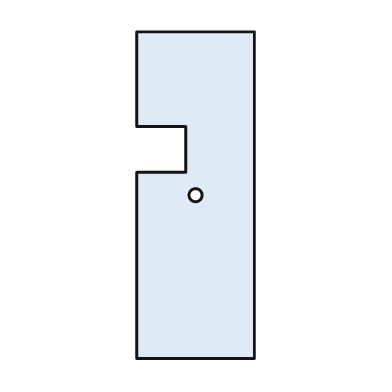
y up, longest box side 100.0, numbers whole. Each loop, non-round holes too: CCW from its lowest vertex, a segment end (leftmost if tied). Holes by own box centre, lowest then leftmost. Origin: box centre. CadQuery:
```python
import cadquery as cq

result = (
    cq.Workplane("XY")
    .moveTo(-18.0, -50.0)
    .lineTo(18.0, -50.0)
    .lineTo(18.0, 50.0)
    .lineTo(-18.0, 50.0)
    .lineTo(-18.0, 21.0)
    .lineTo(-3.0, 21.0)
    .lineTo(-3.0, 7.0)
    .lineTo(-18.0, 7.0)
    .close()
    .moveTo(0.0, 0.0)
    .circle(2.0)
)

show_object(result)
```